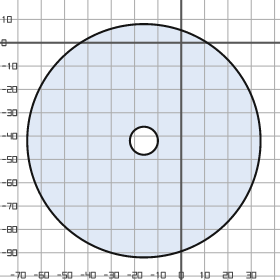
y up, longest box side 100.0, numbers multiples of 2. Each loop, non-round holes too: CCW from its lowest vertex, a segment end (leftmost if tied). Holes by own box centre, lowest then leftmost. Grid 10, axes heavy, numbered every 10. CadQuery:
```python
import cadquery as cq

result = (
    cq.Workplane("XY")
    .moveTo(-16.0, -42.0)
    .circle(50.0)
    .moveTo(-16.0, -42.0)
    .circle(6.0)
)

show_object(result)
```